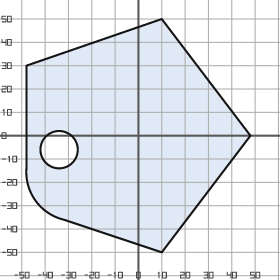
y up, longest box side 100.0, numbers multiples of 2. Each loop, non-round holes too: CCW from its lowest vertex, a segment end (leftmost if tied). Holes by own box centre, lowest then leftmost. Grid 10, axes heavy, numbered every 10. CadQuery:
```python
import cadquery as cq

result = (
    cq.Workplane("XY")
    .moveTo(10.0, -50.0)
    .lineTo(48.0, 0.0)
    .lineTo(10.0, 50.0)
    .lineTo(-48.0, 30.0)
    .lineTo(-48.0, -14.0)
    .threePointArc((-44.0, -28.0), (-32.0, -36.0))
    .close()
    .moveTo(-34.0, -6.0)
    .circle(8.0)
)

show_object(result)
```